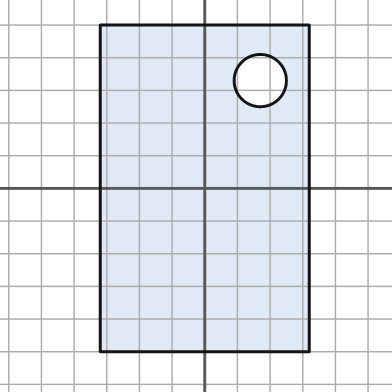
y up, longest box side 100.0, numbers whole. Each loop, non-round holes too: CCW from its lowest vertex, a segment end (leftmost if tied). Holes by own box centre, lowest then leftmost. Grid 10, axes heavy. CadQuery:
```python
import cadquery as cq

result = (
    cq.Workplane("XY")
    .moveTo(-32.0, -50.0)
    .lineTo(32.0, -50.0)
    .lineTo(32.0, 50.0)
    .lineTo(-32.0, 50.0)
    .close()
    .moveTo(17.0, 33.0)
    .circle(8.0)
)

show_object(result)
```